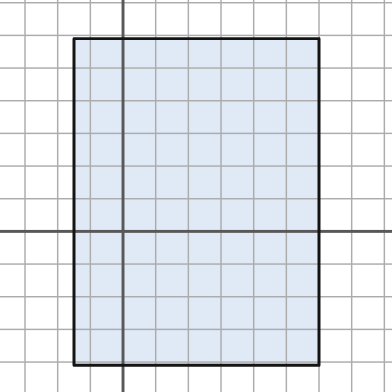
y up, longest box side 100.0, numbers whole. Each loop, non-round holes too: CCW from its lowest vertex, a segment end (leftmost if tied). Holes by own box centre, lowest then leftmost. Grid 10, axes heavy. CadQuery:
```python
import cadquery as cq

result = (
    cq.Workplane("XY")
    .moveTo(-15.0, -41.0)
    .lineTo(60.0, -41.0)
    .lineTo(60.0, 59.0)
    .lineTo(-15.0, 59.0)
    .close()
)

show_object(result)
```